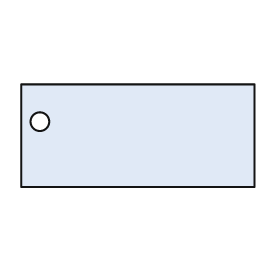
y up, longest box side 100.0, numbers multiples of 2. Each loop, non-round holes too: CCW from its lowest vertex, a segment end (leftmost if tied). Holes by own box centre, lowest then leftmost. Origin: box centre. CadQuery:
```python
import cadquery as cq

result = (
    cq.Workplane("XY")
    .moveTo(-50.0, -22.0)
    .lineTo(50.0, -22.0)
    .lineTo(50.0, 22.0)
    .lineTo(-50.0, 22.0)
    .close()
    .moveTo(-42.0, 6.0)
    .circle(4.0)
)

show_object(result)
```